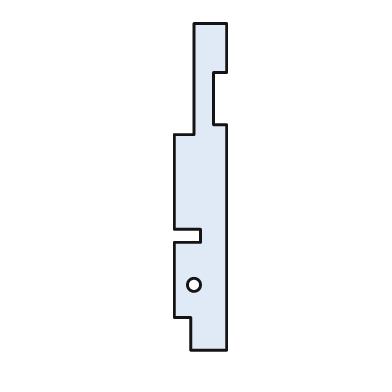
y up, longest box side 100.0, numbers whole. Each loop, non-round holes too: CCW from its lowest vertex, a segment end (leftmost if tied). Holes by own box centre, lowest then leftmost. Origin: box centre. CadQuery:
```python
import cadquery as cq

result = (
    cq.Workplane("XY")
    .moveTo(-3.0, -50.0)
    .lineTo(8.0, -50.0)
    .lineTo(8.0, 19.0)
    .lineTo(4.0, 19.0)
    .lineTo(4.0, 35.0)
    .lineTo(8.0, 35.0)
    .lineTo(8.0, 50.0)
    .lineTo(-2.0, 50.0)
    .lineTo(-2.0, 16.0)
    .lineTo(-8.0, 16.0)
    .lineTo(-8.0, -13.0)
    .lineTo(0.0, -13.0)
    .lineTo(0.0, -17.0)
    .lineTo(-8.0, -17.0)
    .lineTo(-8.0, -40.0)
    .lineTo(-3.0, -40.0)
    .close()
    .moveTo(-2.0, -30.0)
    .circle(2.0)
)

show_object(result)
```